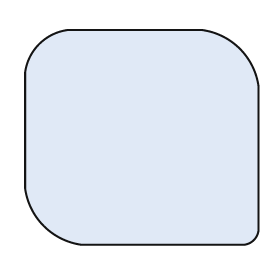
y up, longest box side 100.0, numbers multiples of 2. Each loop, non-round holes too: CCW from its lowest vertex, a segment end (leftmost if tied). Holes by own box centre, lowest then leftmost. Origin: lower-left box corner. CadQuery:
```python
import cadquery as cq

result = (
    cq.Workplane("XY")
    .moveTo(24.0, 0.0)
    .lineTo(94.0, 0.0)
    .threePointArc((98.0, 2.0), (100.0, 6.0))
    .lineTo(100.0, 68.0)
    .threePointArc((92.0, 84.0), (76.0, 92.0))
    .lineTo(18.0, 92.0)
    .threePointArc((6.0, 86.0), (0.0, 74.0))
    .lineTo(0.0, 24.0)
    .threePointArc((8.0, 8.0), (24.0, 0.0))
    .close()
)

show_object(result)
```